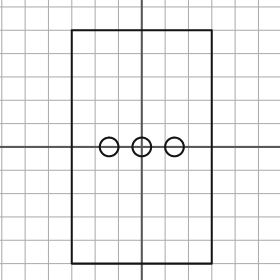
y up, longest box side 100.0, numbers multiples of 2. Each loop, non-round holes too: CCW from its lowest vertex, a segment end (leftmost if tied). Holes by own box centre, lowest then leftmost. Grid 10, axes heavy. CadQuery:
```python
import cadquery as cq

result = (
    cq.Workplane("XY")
    .moveTo(-30.0, -50.0)
    .lineTo(30.0, -50.0)
    .lineTo(30.0, 50.0)
    .lineTo(-30.0, 50.0)
    .close()
    .moveTo(-14.0, 0.0)
    .circle(4.0)
    .moveTo(0.0, 0.0)
    .circle(4.0)
    .moveTo(14.0, 0.0)
    .circle(4.0)
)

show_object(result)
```